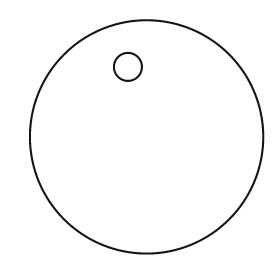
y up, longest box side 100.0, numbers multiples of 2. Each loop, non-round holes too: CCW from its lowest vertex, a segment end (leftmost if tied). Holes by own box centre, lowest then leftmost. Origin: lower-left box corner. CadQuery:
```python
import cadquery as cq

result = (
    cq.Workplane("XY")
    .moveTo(50.0, 50.0)
    .circle(50.0)
    .moveTo(42.0, 80.0)
    .circle(6.0)
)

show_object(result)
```